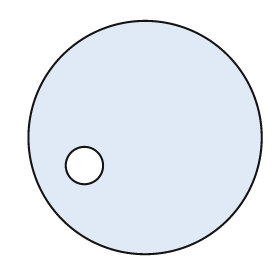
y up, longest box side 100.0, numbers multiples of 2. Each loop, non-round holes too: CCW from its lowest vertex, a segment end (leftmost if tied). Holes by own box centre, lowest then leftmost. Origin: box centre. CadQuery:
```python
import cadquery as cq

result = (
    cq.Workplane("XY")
    .moveTo(0.0, 0.0)
    .circle(50.0)
    .moveTo(-26.0, -12.0)
    .circle(8.0)
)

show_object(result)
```